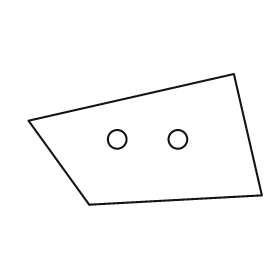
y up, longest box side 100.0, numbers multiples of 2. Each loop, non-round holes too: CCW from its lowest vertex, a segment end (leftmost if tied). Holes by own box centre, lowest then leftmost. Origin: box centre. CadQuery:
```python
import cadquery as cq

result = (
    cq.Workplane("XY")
    .moveTo(-24.0, -28.0)
    .lineTo(50.0, -24.0)
    .lineTo(38.0, 28.0)
    .lineTo(-50.0, 8.0)
    .close()
    .moveTo(-12.0, 0.0)
    .circle(4.0)
    .moveTo(14.0, 0.0)
    .circle(4.0)
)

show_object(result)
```